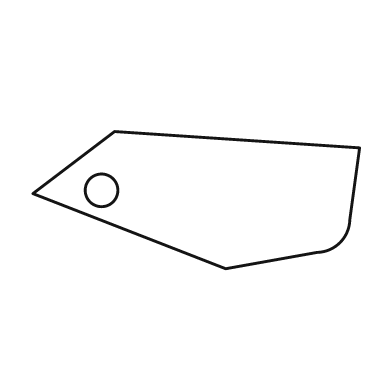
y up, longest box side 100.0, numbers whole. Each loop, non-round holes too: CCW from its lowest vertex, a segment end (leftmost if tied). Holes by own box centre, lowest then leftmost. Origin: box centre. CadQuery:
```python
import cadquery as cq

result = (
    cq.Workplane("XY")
    .moveTo(9.0, -21.0)
    .lineTo(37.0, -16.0)
    .threePointArc((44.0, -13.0), (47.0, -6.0))
    .lineTo(50.0, 16.0)
    .lineTo(-25.0, 21.0)
    .lineTo(-50.0, 2.0)
    .close()
    .moveTo(-29.0, 3.0)
    .circle(5.0)
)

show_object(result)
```